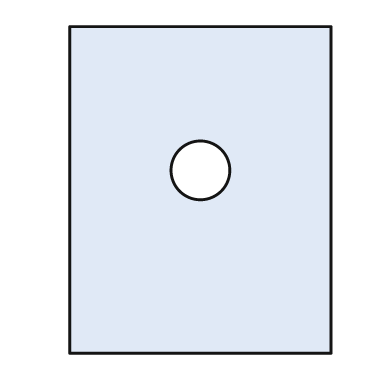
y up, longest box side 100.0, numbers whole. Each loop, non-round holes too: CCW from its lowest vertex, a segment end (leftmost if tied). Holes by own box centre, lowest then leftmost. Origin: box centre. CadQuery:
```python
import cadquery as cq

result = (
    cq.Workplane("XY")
    .moveTo(-40.0, -50.0)
    .lineTo(40.0, -50.0)
    .lineTo(40.0, 50.0)
    .lineTo(-40.0, 50.0)
    .close()
    .moveTo(0.0, 6.0)
    .circle(9.0)
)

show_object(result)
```